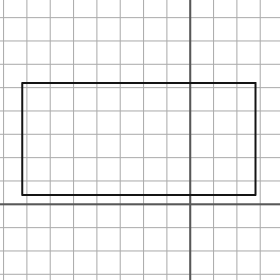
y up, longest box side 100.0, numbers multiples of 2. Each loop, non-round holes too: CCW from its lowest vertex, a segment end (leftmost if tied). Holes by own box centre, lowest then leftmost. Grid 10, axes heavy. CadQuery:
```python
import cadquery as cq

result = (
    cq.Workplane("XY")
    .moveTo(-72.0, 4.0)
    .lineTo(28.0, 4.0)
    .lineTo(28.0, 52.0)
    .lineTo(-72.0, 52.0)
    .close()
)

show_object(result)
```